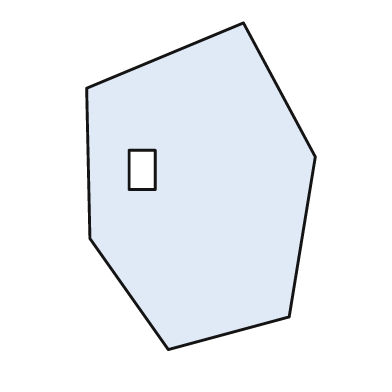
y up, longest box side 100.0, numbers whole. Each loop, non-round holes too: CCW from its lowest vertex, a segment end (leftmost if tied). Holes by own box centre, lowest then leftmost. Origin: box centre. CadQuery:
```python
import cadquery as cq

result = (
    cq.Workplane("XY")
    .moveTo(-10.0, -50.0)
    .lineTo(27.0, -40.0)
    .lineTo(35.0, 9.0)
    .lineTo(13.0, 50.0)
    .lineTo(-35.0, 30.0)
    .lineTo(-34.0, -16.0)
    .close()
    .moveTo(-22.0, -1.0)
    .lineTo(-14.0, -1.0)
    .lineTo(-14.0, 11.0)
    .lineTo(-22.0, 11.0)
    .close()
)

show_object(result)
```